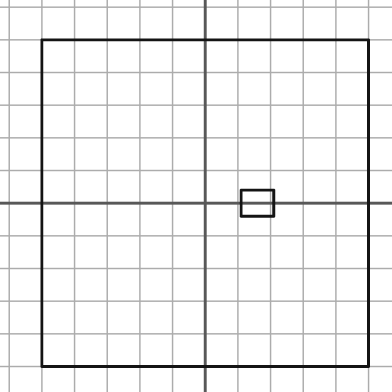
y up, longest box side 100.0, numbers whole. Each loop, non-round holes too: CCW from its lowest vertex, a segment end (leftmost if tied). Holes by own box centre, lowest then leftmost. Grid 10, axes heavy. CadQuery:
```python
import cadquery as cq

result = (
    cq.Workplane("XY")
    .moveTo(-50.0, -50.0)
    .lineTo(50.0, -50.0)
    .lineTo(50.0, 50.0)
    .lineTo(-50.0, 50.0)
    .close()
    .moveTo(11.0, -4.0)
    .lineTo(21.0, -4.0)
    .lineTo(21.0, 4.0)
    .lineTo(11.0, 4.0)
    .close()
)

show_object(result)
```